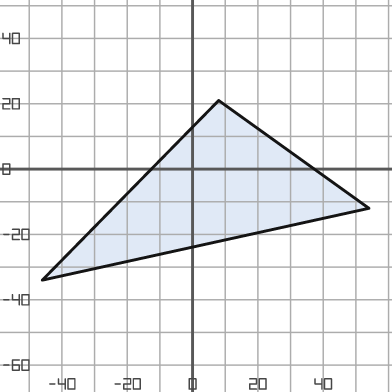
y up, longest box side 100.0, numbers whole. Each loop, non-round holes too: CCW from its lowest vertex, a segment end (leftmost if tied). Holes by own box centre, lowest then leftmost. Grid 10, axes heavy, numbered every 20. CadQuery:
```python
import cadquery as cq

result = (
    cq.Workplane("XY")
    .moveTo(-46.0, -34.0)
    .lineTo(54.0, -12.0)
    .lineTo(8.0, 21.0)
    .close()
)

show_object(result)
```